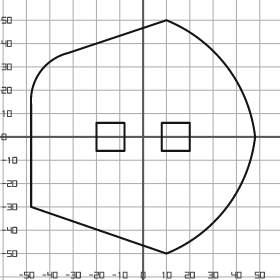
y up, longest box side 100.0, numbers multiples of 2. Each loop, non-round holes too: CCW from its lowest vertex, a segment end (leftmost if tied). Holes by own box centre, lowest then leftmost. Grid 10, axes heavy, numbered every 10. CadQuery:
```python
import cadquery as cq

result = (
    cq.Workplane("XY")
    .moveTo(10.0, -50.0)
    .threePointArc((36.0, -30.0), (48.0, 0.0))
    .threePointArc((36.0, 30.0), (10.0, 50.0))
    .lineTo(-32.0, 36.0)
    .threePointArc((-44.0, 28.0), (-48.0, 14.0))
    .lineTo(-48.0, -30.0)
    .close()
    .moveTo(-20.0, -6.0)
    .lineTo(-8.0, -6.0)
    .lineTo(-8.0, 6.0)
    .lineTo(-20.0, 6.0)
    .close()
    .moveTo(8.0, -6.0)
    .lineTo(20.0, -6.0)
    .lineTo(20.0, 6.0)
    .lineTo(8.0, 6.0)
    .close()
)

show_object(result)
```